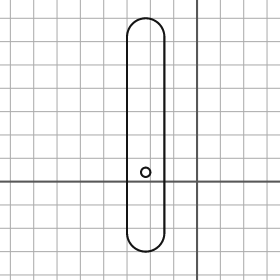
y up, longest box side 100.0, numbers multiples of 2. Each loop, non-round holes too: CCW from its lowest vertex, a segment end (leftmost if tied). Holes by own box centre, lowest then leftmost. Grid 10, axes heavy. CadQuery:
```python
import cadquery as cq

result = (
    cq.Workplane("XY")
    .moveTo(-30.0, -22.0)
    .threePointArc((-22.0, -30.0), (-14.0, -22.0))
    .lineTo(-14.0, 62.0)
    .threePointArc((-22.0, 70.0), (-30.0, 62.0))
    .close()
    .moveTo(-22.0, 4.0)
    .circle(2.0)
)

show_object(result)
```